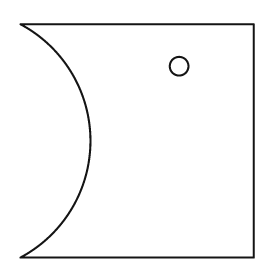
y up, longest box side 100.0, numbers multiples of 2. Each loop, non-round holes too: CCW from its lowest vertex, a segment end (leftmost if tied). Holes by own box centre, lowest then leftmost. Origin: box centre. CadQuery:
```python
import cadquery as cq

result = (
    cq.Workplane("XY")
    .moveTo(-50.0, -50.0)
    .lineTo(50.0, -50.0)
    .lineTo(50.0, 50.0)
    .lineTo(-50.0, 50.0)
    .threePointArc((-20.0, 0.0), (-50.0, -50.0))
    .close()
    .moveTo(18.0, 32.0)
    .circle(4.0)
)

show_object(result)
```